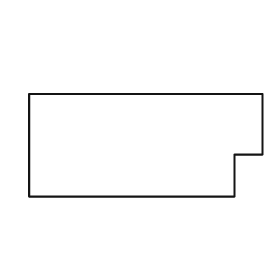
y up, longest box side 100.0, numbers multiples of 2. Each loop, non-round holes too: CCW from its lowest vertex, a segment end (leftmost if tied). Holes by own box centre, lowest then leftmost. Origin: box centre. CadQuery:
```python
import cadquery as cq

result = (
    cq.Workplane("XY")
    .moveTo(-50.0, -22.0)
    .lineTo(38.0, -22.0)
    .lineTo(38.0, -4.0)
    .lineTo(50.0, -4.0)
    .lineTo(50.0, 22.0)
    .lineTo(-50.0, 22.0)
    .close()
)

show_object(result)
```